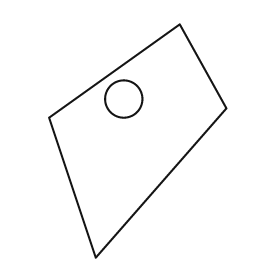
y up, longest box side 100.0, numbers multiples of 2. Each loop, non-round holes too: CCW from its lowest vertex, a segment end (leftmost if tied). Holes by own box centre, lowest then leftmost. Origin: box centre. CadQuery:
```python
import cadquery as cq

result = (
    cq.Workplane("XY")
    .moveTo(-18.0, -50.0)
    .lineTo(38.0, 14.0)
    .lineTo(18.0, 50.0)
    .lineTo(-38.0, 10.0)
    .close()
    .moveTo(-6.0, 18.0)
    .circle(8.0)
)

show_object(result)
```